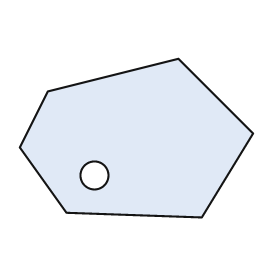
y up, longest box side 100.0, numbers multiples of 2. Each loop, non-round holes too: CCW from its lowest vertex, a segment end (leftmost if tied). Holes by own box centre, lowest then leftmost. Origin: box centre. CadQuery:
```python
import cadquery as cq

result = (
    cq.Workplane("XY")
    .moveTo(28.0, -34.0)
    .lineTo(50.0, 2.0)
    .lineTo(18.0, 34.0)
    .lineTo(-38.0, 20.0)
    .lineTo(-50.0, -4.0)
    .lineTo(-30.0, -32.0)
    .close()
    .moveTo(-18.0, -16.0)
    .circle(6.0)
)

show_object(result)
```